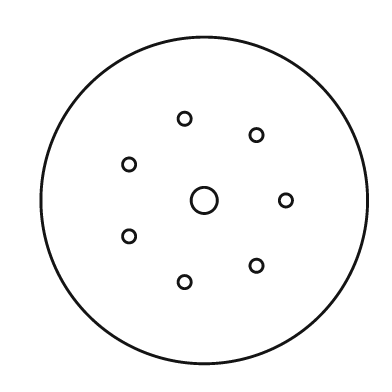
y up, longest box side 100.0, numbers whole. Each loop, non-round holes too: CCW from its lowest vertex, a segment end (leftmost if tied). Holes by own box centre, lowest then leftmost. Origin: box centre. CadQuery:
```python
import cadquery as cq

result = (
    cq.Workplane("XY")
    .moveTo(0.0, 0.0)
    .circle(50.0)
    .moveTo(-6.0, -25.0)
    .circle(2.0)
    .moveTo(16.0, -20.0)
    .circle(2.0)
    .moveTo(-23.0, -11.0)
    .circle(2.0)
    .moveTo(0.0, 0.0)
    .circle(4.0)
    .moveTo(25.0, 0.0)
    .circle(2.0)
    .moveTo(-23.0, 11.0)
    .circle(2.0)
    .moveTo(16.0, 20.0)
    .circle(2.0)
    .moveTo(-6.0, 25.0)
    .circle(2.0)
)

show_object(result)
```